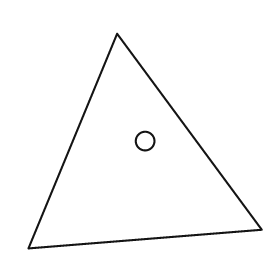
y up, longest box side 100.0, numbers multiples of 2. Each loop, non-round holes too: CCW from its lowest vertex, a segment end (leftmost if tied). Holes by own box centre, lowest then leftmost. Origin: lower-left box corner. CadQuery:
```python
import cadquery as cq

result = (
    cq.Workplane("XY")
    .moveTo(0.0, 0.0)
    .lineTo(100.0, 8.0)
    .lineTo(38.0, 92.0)
    .close()
    .moveTo(50.0, 46.0)
    .circle(4.0)
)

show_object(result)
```